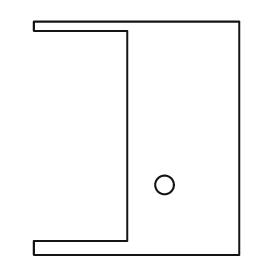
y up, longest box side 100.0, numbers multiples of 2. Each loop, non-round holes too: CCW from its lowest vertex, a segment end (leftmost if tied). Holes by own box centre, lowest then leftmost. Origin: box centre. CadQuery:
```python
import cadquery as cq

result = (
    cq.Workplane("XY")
    .moveTo(-44.0, -50.0)
    .lineTo(44.0, -50.0)
    .lineTo(44.0, 50.0)
    .lineTo(-44.0, 50.0)
    .lineTo(-44.0, 46.0)
    .lineTo(-4.0, 46.0)
    .lineTo(-4.0, -44.0)
    .lineTo(-44.0, -44.0)
    .close()
    .moveTo(12.0, -20.0)
    .circle(4.0)
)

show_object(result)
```